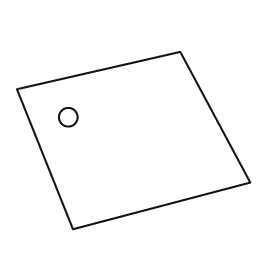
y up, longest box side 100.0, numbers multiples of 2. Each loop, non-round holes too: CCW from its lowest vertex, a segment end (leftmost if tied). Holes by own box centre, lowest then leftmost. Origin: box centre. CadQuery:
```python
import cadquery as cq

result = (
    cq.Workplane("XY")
    .moveTo(-26.0, -38.0)
    .lineTo(50.0, -18.0)
    .lineTo(20.0, 38.0)
    .lineTo(-50.0, 22.0)
    .close()
    .moveTo(-28.0, 10.0)
    .circle(4.0)
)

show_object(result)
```